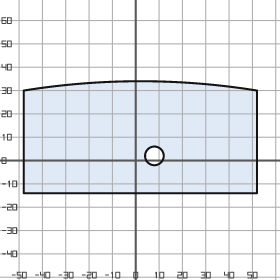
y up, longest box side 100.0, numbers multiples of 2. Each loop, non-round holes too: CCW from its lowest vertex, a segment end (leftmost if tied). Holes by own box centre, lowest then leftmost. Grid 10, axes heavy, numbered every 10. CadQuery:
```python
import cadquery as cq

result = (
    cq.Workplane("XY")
    .moveTo(-48.0, -14.0)
    .lineTo(52.0, -14.0)
    .lineTo(52.0, 30.0)
    .threePointArc((2.0, 34.0), (-48.0, 30.0))
    .close()
    .moveTo(8.0, 2.0)
    .circle(4.0)
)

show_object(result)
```